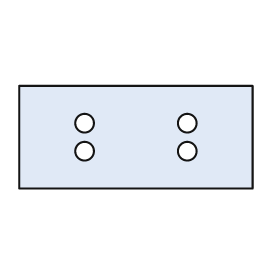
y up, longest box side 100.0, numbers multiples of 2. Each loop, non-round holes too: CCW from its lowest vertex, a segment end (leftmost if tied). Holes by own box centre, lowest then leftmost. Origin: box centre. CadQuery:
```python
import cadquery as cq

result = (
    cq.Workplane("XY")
    .moveTo(-50.0, -22.0)
    .lineTo(50.0, -22.0)
    .lineTo(50.0, 22.0)
    .lineTo(-50.0, 22.0)
    .close()
    .moveTo(-22.0, -6.0)
    .circle(4.0)
    .moveTo(22.0, -6.0)
    .circle(4.0)
    .moveTo(-22.0, 6.0)
    .circle(4.0)
    .moveTo(22.0, 6.0)
    .circle(4.0)
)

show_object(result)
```